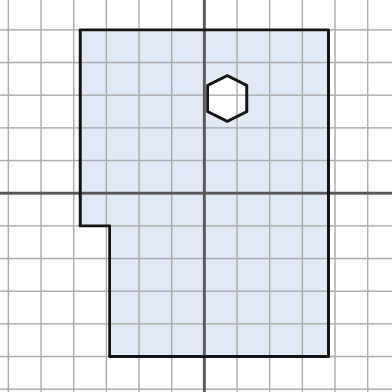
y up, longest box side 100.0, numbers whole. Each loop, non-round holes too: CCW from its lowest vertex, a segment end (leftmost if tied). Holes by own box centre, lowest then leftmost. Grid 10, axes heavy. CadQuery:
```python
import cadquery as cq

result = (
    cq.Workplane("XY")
    .moveTo(-29.0, -50.0)
    .lineTo(38.0, -50.0)
    .lineTo(38.0, 50.0)
    .lineTo(-38.0, 50.0)
    .lineTo(-38.0, -10.0)
    .lineTo(-29.0, -10.0)
    .close()
    .moveTo(7.0, 22.0)
    .lineTo(13.0, 25.0)
    .lineTo(13.0, 33.0)
    .lineTo(7.0, 36.0)
    .lineTo(1.0, 33.0)
    .lineTo(1.0, 25.0)
    .close()
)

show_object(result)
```